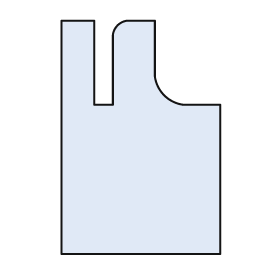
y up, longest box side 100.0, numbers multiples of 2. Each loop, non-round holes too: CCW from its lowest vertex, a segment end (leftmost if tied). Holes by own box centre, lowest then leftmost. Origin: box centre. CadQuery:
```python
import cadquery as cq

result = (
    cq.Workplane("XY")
    .moveTo(-34.0, -50.0)
    .lineTo(34.0, -50.0)
    .lineTo(34.0, 14.0)
    .lineTo(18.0, 14.0)
    .threePointArc((10.0, 18.0), (6.0, 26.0))
    .lineTo(6.0, 50.0)
    .lineTo(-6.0, 50.0)
    .threePointArc((-10.0, 48.0), (-12.0, 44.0))
    .lineTo(-12.0, 14.0)
    .lineTo(-20.0, 14.0)
    .lineTo(-20.0, 50.0)
    .lineTo(-34.0, 50.0)
    .close()
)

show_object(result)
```